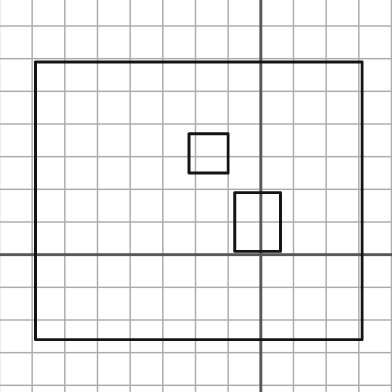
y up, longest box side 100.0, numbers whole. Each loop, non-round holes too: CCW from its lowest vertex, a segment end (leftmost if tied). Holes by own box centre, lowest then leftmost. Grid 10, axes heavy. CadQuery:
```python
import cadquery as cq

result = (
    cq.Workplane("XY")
    .moveTo(-69.0, -26.0)
    .lineTo(31.0, -26.0)
    .lineTo(31.0, 59.0)
    .lineTo(-69.0, 59.0)
    .close()
    .moveTo(-8.0, 1.0)
    .lineTo(6.0, 1.0)
    .lineTo(6.0, 19.0)
    .lineTo(-8.0, 19.0)
    .close()
    .moveTo(-22.0, 25.0)
    .lineTo(-10.0, 25.0)
    .lineTo(-10.0, 37.0)
    .lineTo(-22.0, 37.0)
    .close()
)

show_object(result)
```